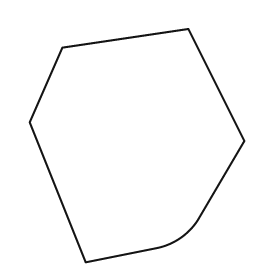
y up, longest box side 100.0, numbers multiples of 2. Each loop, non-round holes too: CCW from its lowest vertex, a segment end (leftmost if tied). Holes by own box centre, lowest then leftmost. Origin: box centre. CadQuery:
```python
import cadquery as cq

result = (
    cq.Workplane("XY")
    .moveTo(-22.0, -50.0)
    .lineTo(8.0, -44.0)
    .threePointArc((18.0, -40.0), (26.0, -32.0))
    .lineTo(46.0, 2.0)
    .lineTo(22.0, 50.0)
    .lineTo(-32.0, 42.0)
    .lineTo(-46.0, 10.0)
    .close()
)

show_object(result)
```